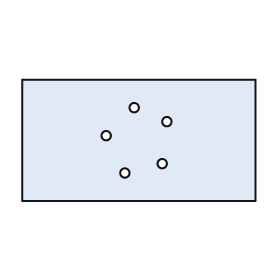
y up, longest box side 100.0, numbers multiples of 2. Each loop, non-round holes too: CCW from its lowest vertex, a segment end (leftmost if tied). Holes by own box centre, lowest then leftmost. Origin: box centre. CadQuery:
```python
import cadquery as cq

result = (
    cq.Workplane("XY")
    .moveTo(-50.0, -26.0)
    .lineTo(50.0, -26.0)
    .lineTo(50.0, 26.0)
    .lineTo(-50.0, 26.0)
    .close()
    .moveTo(-6.0, -14.0)
    .circle(2.0)
    .moveTo(10.0, -10.0)
    .circle(2.0)
    .moveTo(-14.0, 2.0)
    .circle(2.0)
    .moveTo(12.0, 8.0)
    .circle(2.0)
    .moveTo(-2.0, 14.0)
    .circle(2.0)
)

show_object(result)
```